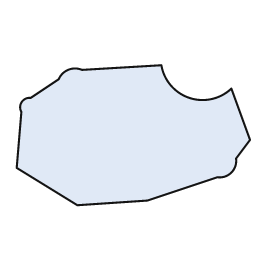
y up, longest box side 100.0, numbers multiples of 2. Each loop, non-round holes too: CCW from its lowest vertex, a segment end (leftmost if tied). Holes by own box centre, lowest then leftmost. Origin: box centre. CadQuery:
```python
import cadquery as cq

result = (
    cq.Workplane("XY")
    .moveTo(-24.0, -30.0)
    .lineTo(6.0, -28.0)
    .lineTo(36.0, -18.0)
    .threePointArc((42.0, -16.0), (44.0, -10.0))
    .lineTo(50.0, -2.0)
    .lineTo(42.0, 20.0)
    .threePointArc((24.0, 16.0), (12.0, 30.0))
    .lineTo(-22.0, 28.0)
    .threePointArc((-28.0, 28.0), (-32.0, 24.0))
    .lineTo(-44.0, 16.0)
    .threePointArc((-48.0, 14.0), (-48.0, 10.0))
    .lineTo(-50.0, -14.0)
    .close()
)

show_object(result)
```